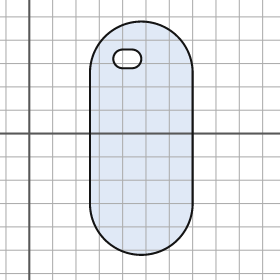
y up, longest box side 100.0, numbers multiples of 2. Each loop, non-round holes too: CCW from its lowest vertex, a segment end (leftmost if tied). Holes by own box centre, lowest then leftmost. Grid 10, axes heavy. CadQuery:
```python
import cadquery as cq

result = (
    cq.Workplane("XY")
    .moveTo(26.0, -30.0)
    .threePointArc((48.0, -52.0), (70.0, -30.0))
    .lineTo(70.0, 26.0)
    .threePointArc((48.0, 48.0), (26.0, 26.0))
    .close()
    .moveTo(40.0, 28.0)
    .lineTo(44.0, 28.0)
    .threePointArc((48.0, 32.0), (44.0, 36.0))
    .lineTo(40.0, 36.0)
    .threePointArc((36.0, 32.0), (40.0, 28.0))
    .close()
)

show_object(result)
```